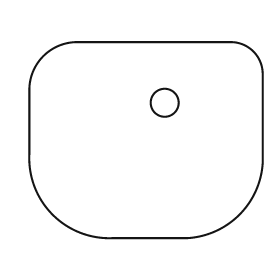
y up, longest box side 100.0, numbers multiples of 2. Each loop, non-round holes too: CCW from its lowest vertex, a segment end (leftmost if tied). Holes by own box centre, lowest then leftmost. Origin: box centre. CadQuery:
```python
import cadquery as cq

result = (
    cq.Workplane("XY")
    .moveTo(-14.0, -42.0)
    .lineTo(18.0, -42.0)
    .threePointArc((40.0, -32.0), (50.0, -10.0))
    .lineTo(50.0, 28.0)
    .threePointArc((46.0, 38.0), (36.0, 42.0))
    .lineTo(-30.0, 42.0)
    .threePointArc((-44.0, 36.0), (-50.0, 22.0))
    .lineTo(-50.0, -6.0)
    .threePointArc((-40.0, -32.0), (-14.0, -42.0))
    .close()
    .moveTo(8.0, 16.0)
    .circle(6.0)
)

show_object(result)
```